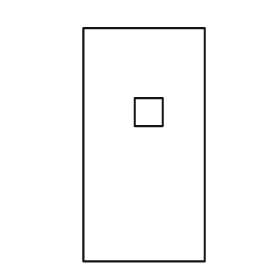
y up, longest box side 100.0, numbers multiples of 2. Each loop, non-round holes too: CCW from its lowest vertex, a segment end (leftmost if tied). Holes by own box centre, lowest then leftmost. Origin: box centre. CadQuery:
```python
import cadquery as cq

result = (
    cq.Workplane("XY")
    .moveTo(-26.0, -50.0)
    .lineTo(26.0, -50.0)
    .lineTo(26.0, 50.0)
    .lineTo(-26.0, 50.0)
    .close()
    .moveTo(-4.0, 8.0)
    .lineTo(8.0, 8.0)
    .lineTo(8.0, 20.0)
    .lineTo(-4.0, 20.0)
    .close()
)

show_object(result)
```